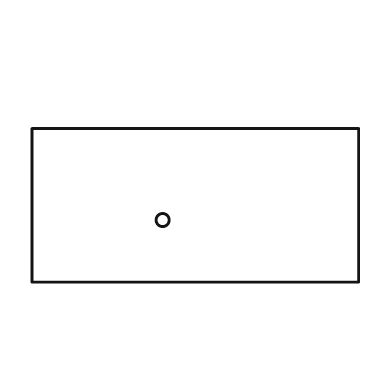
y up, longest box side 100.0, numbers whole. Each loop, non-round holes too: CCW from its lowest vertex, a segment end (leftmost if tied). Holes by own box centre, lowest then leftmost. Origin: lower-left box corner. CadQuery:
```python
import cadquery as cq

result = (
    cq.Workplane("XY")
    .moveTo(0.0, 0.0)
    .lineTo(100.0, 0.0)
    .lineTo(100.0, 47.0)
    .lineTo(0.0, 47.0)
    .close()
    .moveTo(40.0, 19.0)
    .circle(2.0)
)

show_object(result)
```